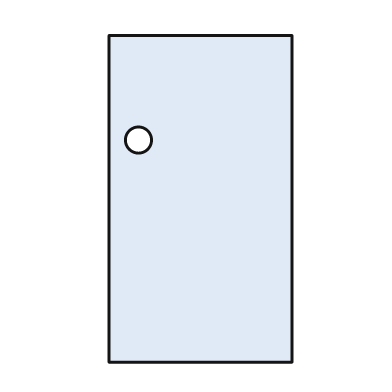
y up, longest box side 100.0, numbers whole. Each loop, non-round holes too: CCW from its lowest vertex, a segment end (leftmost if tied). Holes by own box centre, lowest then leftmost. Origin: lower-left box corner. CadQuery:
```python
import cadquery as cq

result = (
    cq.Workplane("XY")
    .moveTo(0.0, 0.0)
    .lineTo(56.0, 0.0)
    .lineTo(56.0, 100.0)
    .lineTo(0.0, 100.0)
    .close()
    .moveTo(9.0, 68.0)
    .circle(4.0)
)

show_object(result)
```